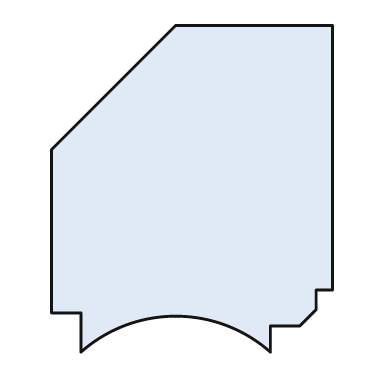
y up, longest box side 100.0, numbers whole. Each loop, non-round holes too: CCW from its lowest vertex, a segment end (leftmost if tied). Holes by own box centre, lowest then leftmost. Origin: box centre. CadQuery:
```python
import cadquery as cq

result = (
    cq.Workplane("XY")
    .moveTo(-34.0, -50.0)
    .threePointArc((-5.0, -39.0), (24.0, -50.0))
    .lineTo(24.0, -42.0)
    .lineTo(33.0, -42.0)
    .lineTo(38.0, -37.0)
    .lineTo(38.0, -31.0)
    .lineTo(43.0, -31.0)
    .lineTo(43.0, 50.0)
    .lineTo(-5.0, 50.0)
    .lineTo(-43.0, 12.0)
    .lineTo(-43.0, -38.0)
    .lineTo(-34.0, -38.0)
    .close()
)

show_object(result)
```